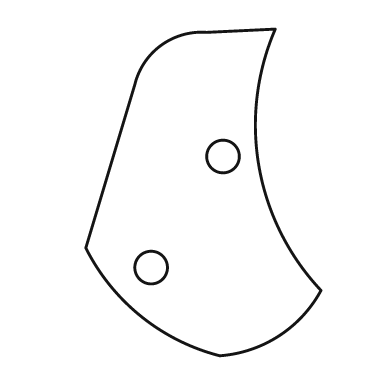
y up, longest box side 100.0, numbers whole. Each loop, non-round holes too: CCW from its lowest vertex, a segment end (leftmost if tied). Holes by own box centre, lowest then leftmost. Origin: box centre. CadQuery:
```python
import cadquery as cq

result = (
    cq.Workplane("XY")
    .moveTo(5.0, -50.0)
    .threePointArc((23.0, -44.0), (36.0, -30.0))
    .threePointArc((17.0, 8.0), (22.0, 50.0))
    .lineTo(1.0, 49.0)
    .threePointArc((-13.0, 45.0), (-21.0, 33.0))
    .lineTo(-36.0, -17.0)
    .threePointArc((-19.0, -38.0), (5.0, -50.0))
    .close()
    .moveTo(-16.0, -23.0)
    .circle(5.0)
    .moveTo(6.0, 11.0)
    .circle(5.0)
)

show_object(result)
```